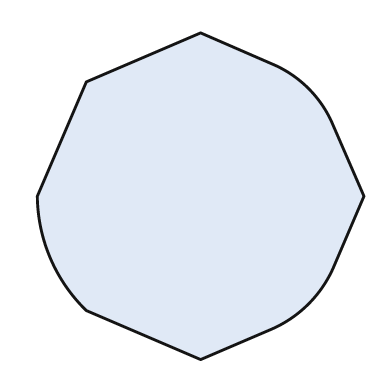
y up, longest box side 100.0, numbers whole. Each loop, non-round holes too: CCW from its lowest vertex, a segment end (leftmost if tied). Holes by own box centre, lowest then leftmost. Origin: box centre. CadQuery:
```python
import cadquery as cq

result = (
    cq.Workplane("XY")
    .moveTo(0.0, -50.0)
    .lineTo(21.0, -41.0)
    .threePointArc((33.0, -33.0), (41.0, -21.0))
    .lineTo(50.0, 0.0)
    .lineTo(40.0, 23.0)
    .threePointArc((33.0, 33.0), (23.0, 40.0))
    .lineTo(0.0, 50.0)
    .lineTo(-35.0, 35.0)
    .lineTo(-50.0, 0.0)
    .threePointArc((-46.0, -19.0), (-35.0, -35.0))
    .close()
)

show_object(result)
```